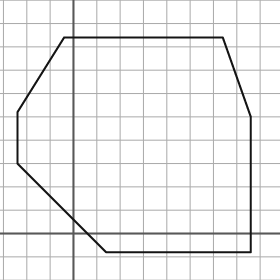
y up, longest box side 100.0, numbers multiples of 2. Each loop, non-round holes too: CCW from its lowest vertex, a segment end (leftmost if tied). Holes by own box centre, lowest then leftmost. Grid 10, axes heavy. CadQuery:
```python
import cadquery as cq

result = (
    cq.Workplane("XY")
    .moveTo(14.0, -8.0)
    .lineTo(76.0, -8.0)
    .lineTo(76.0, 50.0)
    .lineTo(64.0, 84.0)
    .lineTo(-4.0, 84.0)
    .lineTo(-24.0, 52.0)
    .lineTo(-24.0, 30.0)
    .close()
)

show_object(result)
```